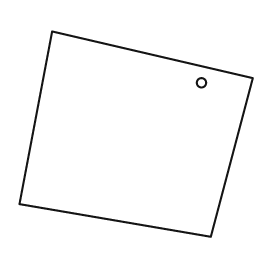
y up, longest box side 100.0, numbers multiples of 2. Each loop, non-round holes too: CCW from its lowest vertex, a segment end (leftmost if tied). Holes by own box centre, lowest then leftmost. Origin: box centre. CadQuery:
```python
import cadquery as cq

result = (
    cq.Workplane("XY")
    .moveTo(32.0, -44.0)
    .lineTo(50.0, 24.0)
    .lineTo(-36.0, 44.0)
    .lineTo(-50.0, -30.0)
    .close()
    .moveTo(28.0, 22.0)
    .circle(2.0)
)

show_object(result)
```